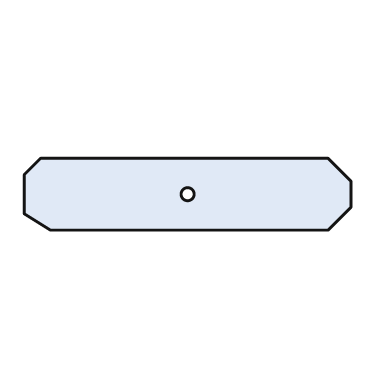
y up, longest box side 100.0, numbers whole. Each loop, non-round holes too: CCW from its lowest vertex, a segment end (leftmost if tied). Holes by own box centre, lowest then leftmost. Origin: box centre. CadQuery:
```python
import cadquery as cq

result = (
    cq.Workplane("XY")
    .moveTo(-42.0, -11.0)
    .lineTo(43.0, -11.0)
    .lineTo(50.0, -4.0)
    .lineTo(50.0, 4.0)
    .lineTo(43.0, 11.0)
    .lineTo(-45.0, 11.0)
    .lineTo(-50.0, 6.0)
    .lineTo(-50.0, -6.0)
    .close()
    .moveTo(0.0, 0.0)
    .circle(2.0)
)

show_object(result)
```